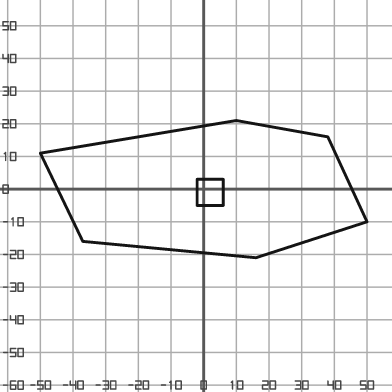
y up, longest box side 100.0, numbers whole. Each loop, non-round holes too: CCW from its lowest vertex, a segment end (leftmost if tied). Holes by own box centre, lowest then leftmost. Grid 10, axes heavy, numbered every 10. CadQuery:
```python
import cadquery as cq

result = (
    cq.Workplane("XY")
    .moveTo(16.0, -21.0)
    .lineTo(50.0, -10.0)
    .lineTo(38.0, 16.0)
    .lineTo(10.0, 21.0)
    .lineTo(-50.0, 11.0)
    .lineTo(-37.0, -16.0)
    .close()
    .moveTo(-2.0, -5.0)
    .lineTo(6.0, -5.0)
    .lineTo(6.0, 3.0)
    .lineTo(-2.0, 3.0)
    .close()
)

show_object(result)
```